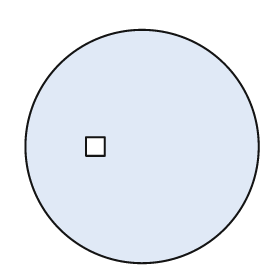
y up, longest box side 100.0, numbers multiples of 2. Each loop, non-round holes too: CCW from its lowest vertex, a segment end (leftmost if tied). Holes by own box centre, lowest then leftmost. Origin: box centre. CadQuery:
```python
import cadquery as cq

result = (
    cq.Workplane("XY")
    .moveTo(0.0, 0.0)
    .circle(50.0)
    .moveTo(-24.0, -4.0)
    .lineTo(-16.0, -4.0)
    .lineTo(-16.0, 4.0)
    .lineTo(-24.0, 4.0)
    .close()
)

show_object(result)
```